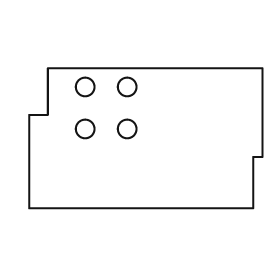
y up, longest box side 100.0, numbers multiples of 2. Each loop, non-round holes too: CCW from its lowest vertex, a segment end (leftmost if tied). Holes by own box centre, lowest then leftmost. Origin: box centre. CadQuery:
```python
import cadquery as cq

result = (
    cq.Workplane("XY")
    .moveTo(-50.0, -30.0)
    .lineTo(46.0, -30.0)
    .lineTo(46.0, -8.0)
    .lineTo(50.0, -8.0)
    .lineTo(50.0, 30.0)
    .lineTo(-42.0, 30.0)
    .lineTo(-42.0, 10.0)
    .lineTo(-50.0, 10.0)
    .close()
    .moveTo(-26.0, 4.0)
    .circle(4.0)
    .moveTo(-8.0, 4.0)
    .circle(4.0)
    .moveTo(-26.0, 22.0)
    .circle(4.0)
    .moveTo(-8.0, 22.0)
    .circle(4.0)
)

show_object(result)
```